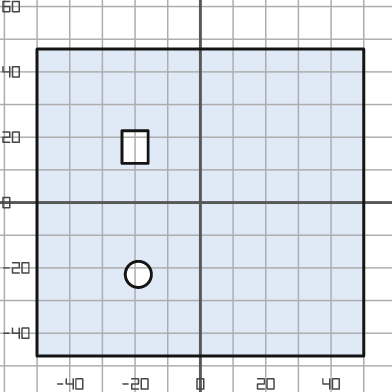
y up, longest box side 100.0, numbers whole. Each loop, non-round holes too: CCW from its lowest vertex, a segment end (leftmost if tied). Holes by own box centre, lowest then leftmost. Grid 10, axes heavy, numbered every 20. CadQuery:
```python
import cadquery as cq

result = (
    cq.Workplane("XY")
    .moveTo(-50.0, -47.0)
    .lineTo(50.0, -47.0)
    .lineTo(50.0, 47.0)
    .lineTo(-50.0, 47.0)
    .close()
    .moveTo(-19.0, -22.0)
    .circle(4.0)
    .moveTo(-24.0, 12.0)
    .lineTo(-16.0, 12.0)
    .lineTo(-16.0, 22.0)
    .lineTo(-24.0, 22.0)
    .close()
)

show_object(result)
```